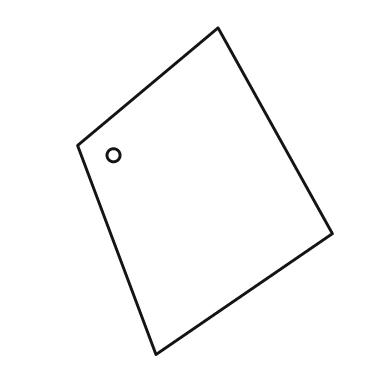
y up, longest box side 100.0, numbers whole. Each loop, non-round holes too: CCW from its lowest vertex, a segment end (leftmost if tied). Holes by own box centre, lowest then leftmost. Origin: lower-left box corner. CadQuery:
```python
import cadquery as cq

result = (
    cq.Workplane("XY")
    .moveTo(24.0, 0.0)
    .lineTo(78.0, 37.0)
    .lineTo(43.0, 100.0)
    .lineTo(0.0, 64.0)
    .close()
    .moveTo(11.0, 61.0)
    .circle(2.0)
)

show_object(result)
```